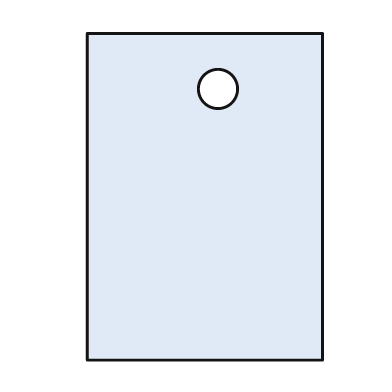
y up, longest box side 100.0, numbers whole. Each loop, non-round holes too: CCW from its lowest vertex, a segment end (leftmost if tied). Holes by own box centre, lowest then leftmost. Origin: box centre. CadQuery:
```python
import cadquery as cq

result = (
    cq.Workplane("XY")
    .moveTo(-36.0, -50.0)
    .lineTo(36.0, -50.0)
    .lineTo(36.0, 50.0)
    .lineTo(-36.0, 50.0)
    .close()
    .moveTo(4.0, 33.0)
    .circle(6.0)
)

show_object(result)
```